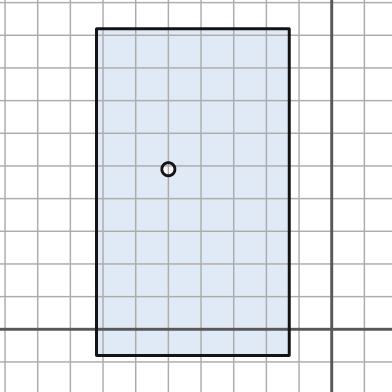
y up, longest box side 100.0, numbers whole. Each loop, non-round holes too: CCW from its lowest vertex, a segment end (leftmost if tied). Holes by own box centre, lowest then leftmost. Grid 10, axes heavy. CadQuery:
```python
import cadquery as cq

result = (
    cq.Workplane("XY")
    .moveTo(-72.0, -8.0)
    .lineTo(-13.0, -8.0)
    .lineTo(-13.0, 92.0)
    .lineTo(-72.0, 92.0)
    .close()
    .moveTo(-50.0, 49.0)
    .circle(2.0)
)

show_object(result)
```